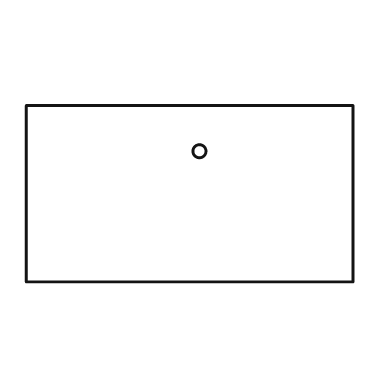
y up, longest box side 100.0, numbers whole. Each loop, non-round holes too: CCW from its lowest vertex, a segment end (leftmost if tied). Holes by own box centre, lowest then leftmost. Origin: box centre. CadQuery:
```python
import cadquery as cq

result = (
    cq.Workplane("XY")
    .moveTo(-50.0, -27.0)
    .lineTo(50.0, -27.0)
    .lineTo(50.0, 27.0)
    .lineTo(-50.0, 27.0)
    .close()
    .moveTo(3.0, 13.0)
    .circle(2.0)
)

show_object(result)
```